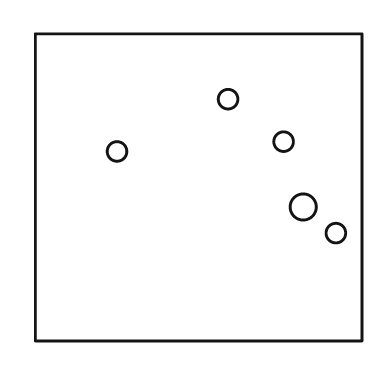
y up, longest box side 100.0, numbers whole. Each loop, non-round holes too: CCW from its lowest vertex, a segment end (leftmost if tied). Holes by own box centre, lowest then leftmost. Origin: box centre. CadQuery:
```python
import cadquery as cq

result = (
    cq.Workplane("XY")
    .moveTo(-50.0, -47.0)
    .lineTo(50.0, -47.0)
    .lineTo(50.0, 47.0)
    .lineTo(-50.0, 47.0)
    .close()
    .moveTo(42.0, -14.0)
    .circle(3.0)
    .moveTo(32.0, -6.0)
    .circle(4.0)
    .moveTo(-25.0, 11.0)
    .circle(3.0)
    .moveTo(26.0, 14.0)
    .circle(3.0)
    .moveTo(9.0, 27.0)
    .circle(3.0)
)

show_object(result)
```